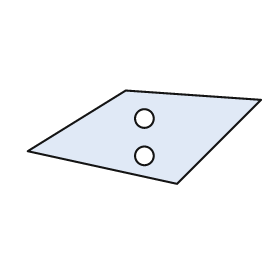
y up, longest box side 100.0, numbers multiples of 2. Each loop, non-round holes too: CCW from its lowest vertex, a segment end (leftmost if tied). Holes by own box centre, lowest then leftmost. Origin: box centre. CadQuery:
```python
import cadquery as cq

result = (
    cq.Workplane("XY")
    .moveTo(14.0, -20.0)
    .lineTo(50.0, 16.0)
    .lineTo(-8.0, 20.0)
    .lineTo(-50.0, -6.0)
    .close()
    .moveTo(0.0, -8.0)
    .circle(4.0)
    .moveTo(0.0, 8.0)
    .circle(4.0)
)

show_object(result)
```